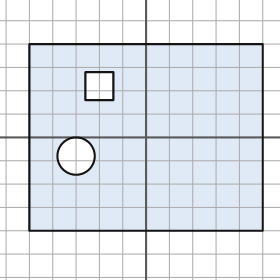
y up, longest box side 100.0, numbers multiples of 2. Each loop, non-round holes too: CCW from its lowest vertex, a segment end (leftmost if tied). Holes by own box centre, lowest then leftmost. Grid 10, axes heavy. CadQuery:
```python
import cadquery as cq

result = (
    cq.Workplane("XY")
    .moveTo(-50.0, -40.0)
    .lineTo(50.0, -40.0)
    .lineTo(50.0, 40.0)
    .lineTo(-50.0, 40.0)
    .close()
    .moveTo(-30.0, -8.0)
    .circle(8.0)
    .moveTo(-26.0, 16.0)
    .lineTo(-14.0, 16.0)
    .lineTo(-14.0, 28.0)
    .lineTo(-26.0, 28.0)
    .close()
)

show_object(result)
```